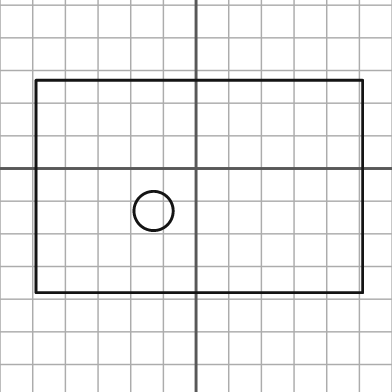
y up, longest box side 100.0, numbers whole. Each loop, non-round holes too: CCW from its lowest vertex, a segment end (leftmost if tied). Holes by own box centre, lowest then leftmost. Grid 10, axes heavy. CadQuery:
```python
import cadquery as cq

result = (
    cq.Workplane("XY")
    .moveTo(-49.0, -38.0)
    .lineTo(51.0, -38.0)
    .lineTo(51.0, 27.0)
    .lineTo(-49.0, 27.0)
    .close()
    .moveTo(-13.0, -13.0)
    .circle(6.0)
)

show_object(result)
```